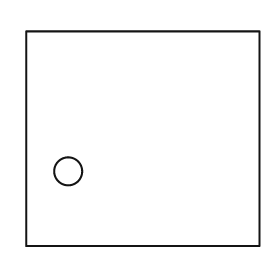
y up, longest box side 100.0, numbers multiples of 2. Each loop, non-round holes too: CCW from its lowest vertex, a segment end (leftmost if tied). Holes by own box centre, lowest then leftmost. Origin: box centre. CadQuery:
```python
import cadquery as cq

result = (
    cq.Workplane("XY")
    .moveTo(-50.0, -46.0)
    .lineTo(50.0, -46.0)
    .lineTo(50.0, 46.0)
    .lineTo(-50.0, 46.0)
    .close()
    .moveTo(-32.0, -14.0)
    .circle(6.0)
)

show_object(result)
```